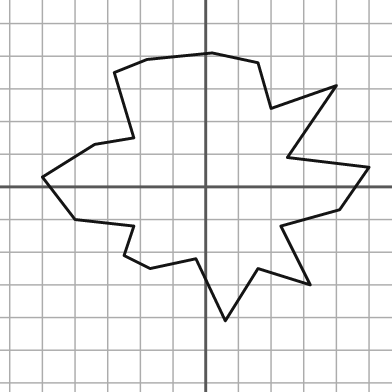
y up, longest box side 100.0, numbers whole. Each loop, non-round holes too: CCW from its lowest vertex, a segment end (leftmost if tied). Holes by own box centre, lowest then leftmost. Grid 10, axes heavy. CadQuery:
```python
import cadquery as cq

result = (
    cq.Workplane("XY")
    .moveTo(6.0, -41.0)
    .lineTo(16.0, -25.0)
    .lineTo(32.0, -30.0)
    .lineTo(23.0, -12.0)
    .lineTo(41.0, -7.0)
    .lineTo(50.0, 6.0)
    .lineTo(25.0, 9.0)
    .lineTo(40.0, 31.0)
    .lineTo(20.0, 24.0)
    .lineTo(16.0, 38.0)
    .lineTo(2.0, 41.0)
    .lineTo(-18.0, 39.0)
    .lineTo(-28.0, 35.0)
    .lineTo(-22.0, 15.0)
    .lineTo(-34.0, 13.0)
    .lineTo(-50.0, 3.0)
    .lineTo(-40.0, -10.0)
    .lineTo(-22.0, -12.0)
    .lineTo(-25.0, -21.0)
    .lineTo(-17.0, -25.0)
    .lineTo(-3.0, -22.0)
    .close()
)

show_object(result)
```